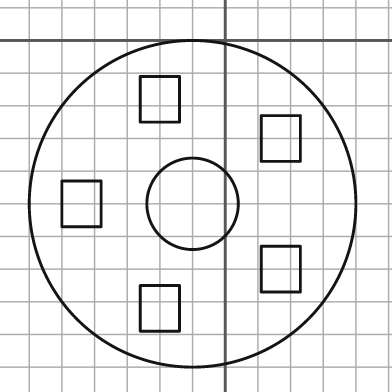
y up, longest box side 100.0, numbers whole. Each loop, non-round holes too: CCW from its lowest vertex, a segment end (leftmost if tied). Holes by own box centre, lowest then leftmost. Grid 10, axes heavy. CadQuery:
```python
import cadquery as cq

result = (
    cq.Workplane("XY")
    .moveTo(-10.0, -50.0)
    .circle(50.0)
    .moveTo(-26.0, -89.0)
    .lineTo(-14.0, -89.0)
    .lineTo(-14.0, -75.0)
    .lineTo(-26.0, -75.0)
    .close()
    .moveTo(11.0, -77.0)
    .lineTo(23.0, -77.0)
    .lineTo(23.0, -63.0)
    .lineTo(11.0, -63.0)
    .close()
    .moveTo(-50.0, -57.0)
    .lineTo(-38.0, -57.0)
    .lineTo(-38.0, -43.0)
    .lineTo(-50.0, -43.0)
    .close()
    .moveTo(-10.0, -50.0)
    .circle(14.0)
    .moveTo(11.0, -37.0)
    .lineTo(23.0, -37.0)
    .lineTo(23.0, -23.0)
    .lineTo(11.0, -23.0)
    .close()
    .moveTo(-26.0, -25.0)
    .lineTo(-14.0, -25.0)
    .lineTo(-14.0, -11.0)
    .lineTo(-26.0, -11.0)
    .close()
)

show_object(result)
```